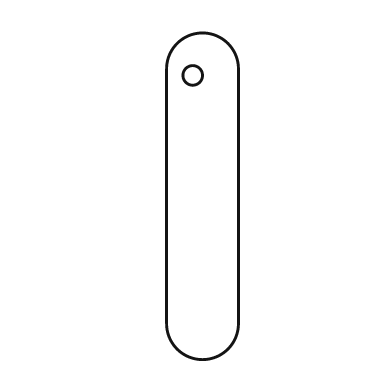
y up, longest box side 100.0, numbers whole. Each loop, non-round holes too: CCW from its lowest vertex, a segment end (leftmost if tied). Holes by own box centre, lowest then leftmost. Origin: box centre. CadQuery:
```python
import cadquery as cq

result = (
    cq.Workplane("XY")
    .moveTo(-11.0, -39.0)
    .threePointArc((0.0, -50.0), (11.0, -39.0))
    .lineTo(11.0, 39.0)
    .threePointArc((0.0, 50.0), (-11.0, 39.0))
    .close()
    .moveTo(-3.0, 37.0)
    .circle(3.0)
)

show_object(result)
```